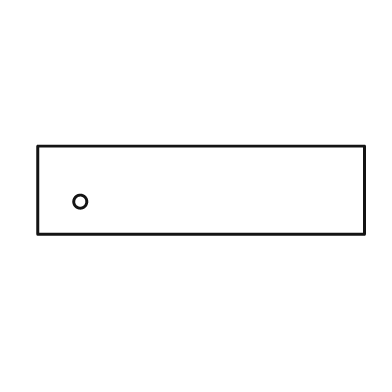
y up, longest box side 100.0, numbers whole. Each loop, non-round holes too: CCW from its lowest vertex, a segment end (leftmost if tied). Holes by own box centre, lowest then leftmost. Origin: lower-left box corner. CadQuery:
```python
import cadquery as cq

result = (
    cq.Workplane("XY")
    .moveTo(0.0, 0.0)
    .lineTo(100.0, 0.0)
    .lineTo(100.0, 27.0)
    .lineTo(0.0, 27.0)
    .close()
    .moveTo(13.0, 10.0)
    .circle(2.0)
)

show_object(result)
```